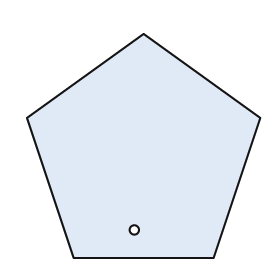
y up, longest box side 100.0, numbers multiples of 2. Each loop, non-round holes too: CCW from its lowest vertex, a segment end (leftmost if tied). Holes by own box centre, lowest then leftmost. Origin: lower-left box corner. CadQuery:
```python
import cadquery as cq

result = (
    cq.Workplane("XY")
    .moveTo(20.0, 0.0)
    .lineTo(80.0, 0.0)
    .lineTo(100.0, 60.0)
    .lineTo(50.0, 96.0)
    .lineTo(0.0, 60.0)
    .close()
    .moveTo(46.0, 12.0)
    .circle(2.0)
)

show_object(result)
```